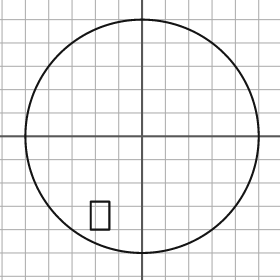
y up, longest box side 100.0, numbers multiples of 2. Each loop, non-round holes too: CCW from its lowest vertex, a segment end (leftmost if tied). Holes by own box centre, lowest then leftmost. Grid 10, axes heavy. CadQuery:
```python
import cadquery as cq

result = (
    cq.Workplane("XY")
    .moveTo(0.0, 0.0)
    .circle(50.0)
    .moveTo(-22.0, -40.0)
    .lineTo(-14.0, -40.0)
    .lineTo(-14.0, -28.0)
    .lineTo(-22.0, -28.0)
    .close()
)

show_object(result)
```